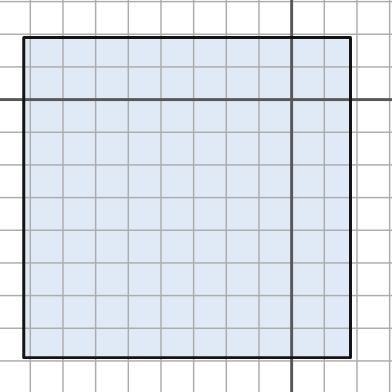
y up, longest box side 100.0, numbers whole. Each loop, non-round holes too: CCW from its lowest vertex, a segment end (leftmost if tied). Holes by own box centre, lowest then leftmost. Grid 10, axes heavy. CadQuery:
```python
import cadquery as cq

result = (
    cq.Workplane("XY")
    .moveTo(-82.0, -79.0)
    .lineTo(18.0, -79.0)
    .lineTo(18.0, 19.0)
    .lineTo(-82.0, 19.0)
    .close()
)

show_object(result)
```